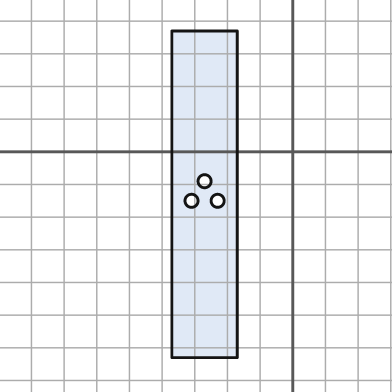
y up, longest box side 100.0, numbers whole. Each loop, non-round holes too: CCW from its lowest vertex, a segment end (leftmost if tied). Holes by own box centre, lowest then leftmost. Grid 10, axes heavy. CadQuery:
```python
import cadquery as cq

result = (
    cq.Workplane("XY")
    .moveTo(-37.0, -63.0)
    .lineTo(-17.0, -63.0)
    .lineTo(-17.0, 37.0)
    .lineTo(-37.0, 37.0)
    .close()
    .moveTo(-31.0, -15.0)
    .circle(2.0)
    .moveTo(-23.0, -15.0)
    .circle(2.0)
    .moveTo(-27.0, -9.0)
    .circle(2.0)
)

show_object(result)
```